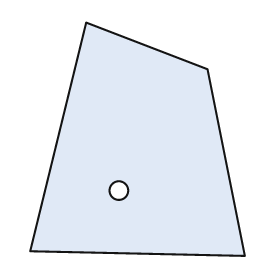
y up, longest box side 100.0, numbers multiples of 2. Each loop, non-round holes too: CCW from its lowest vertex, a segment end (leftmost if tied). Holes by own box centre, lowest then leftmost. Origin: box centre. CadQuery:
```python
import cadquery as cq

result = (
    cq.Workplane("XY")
    .moveTo(46.0, -50.0)
    .lineTo(30.0, 30.0)
    .lineTo(-22.0, 50.0)
    .lineTo(-46.0, -48.0)
    .close()
    .moveTo(-8.0, -22.0)
    .circle(4.0)
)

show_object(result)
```